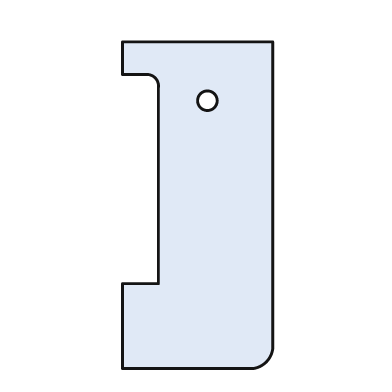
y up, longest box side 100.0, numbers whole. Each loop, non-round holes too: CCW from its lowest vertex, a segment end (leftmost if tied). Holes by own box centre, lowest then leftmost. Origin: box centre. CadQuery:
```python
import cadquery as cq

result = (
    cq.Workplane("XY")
    .moveTo(-23.0, -50.0)
    .lineTo(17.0, -50.0)
    .threePointArc((21.0, -48.0), (23.0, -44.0))
    .lineTo(23.0, 50.0)
    .lineTo(-23.0, 50.0)
    .lineTo(-23.0, 40.0)
    .lineTo(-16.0, 40.0)
    .threePointArc((-13.0, 39.0), (-12.0, 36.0))
    .lineTo(-12.0, -24.0)
    .lineTo(-23.0, -24.0)
    .close()
    .moveTo(3.0, 32.0)
    .circle(3.0)
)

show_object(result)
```